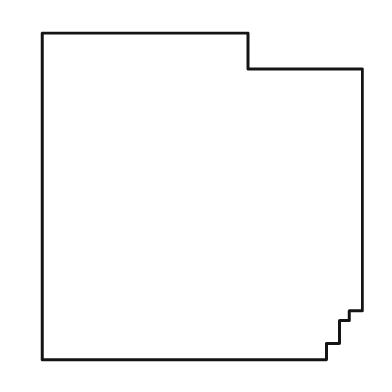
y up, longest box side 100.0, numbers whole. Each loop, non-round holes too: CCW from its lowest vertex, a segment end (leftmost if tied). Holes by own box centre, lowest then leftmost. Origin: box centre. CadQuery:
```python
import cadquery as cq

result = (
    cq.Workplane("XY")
    .moveTo(-49.0, -50.0)
    .lineTo(38.0, -50.0)
    .lineTo(38.0, -45.0)
    .lineTo(42.0, -45.0)
    .lineTo(42.0, -38.0)
    .lineTo(45.0, -38.0)
    .lineTo(45.0, -35.0)
    .lineTo(49.0, -35.0)
    .lineTo(49.0, 39.0)
    .lineTo(14.0, 39.0)
    .lineTo(14.0, 50.0)
    .lineTo(-49.0, 50.0)
    .close()
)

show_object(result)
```